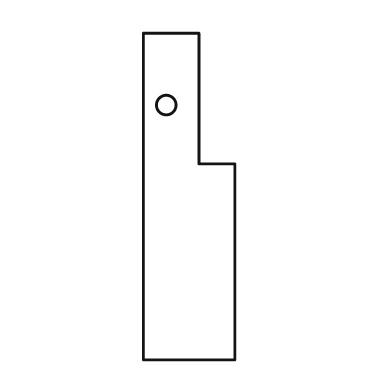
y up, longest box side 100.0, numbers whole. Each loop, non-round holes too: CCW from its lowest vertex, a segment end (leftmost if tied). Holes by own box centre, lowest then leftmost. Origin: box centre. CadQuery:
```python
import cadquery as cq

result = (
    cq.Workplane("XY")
    .moveTo(-14.0, -50.0)
    .lineTo(14.0, -50.0)
    .lineTo(14.0, 10.0)
    .lineTo(3.0, 10.0)
    .lineTo(3.0, 50.0)
    .lineTo(-14.0, 50.0)
    .close()
    .moveTo(-7.0, 28.0)
    .circle(3.0)
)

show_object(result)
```